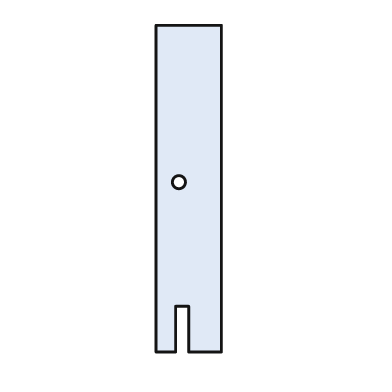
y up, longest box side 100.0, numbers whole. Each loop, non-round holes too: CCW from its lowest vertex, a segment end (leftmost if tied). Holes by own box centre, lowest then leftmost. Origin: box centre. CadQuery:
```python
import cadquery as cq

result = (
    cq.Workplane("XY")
    .moveTo(-10.0, -50.0)
    .lineTo(-4.0, -50.0)
    .lineTo(-4.0, -36.0)
    .lineTo(0.0, -36.0)
    .lineTo(0.0, -50.0)
    .lineTo(10.0, -50.0)
    .lineTo(10.0, 50.0)
    .lineTo(-10.0, 50.0)
    .close()
    .moveTo(-3.0, 2.0)
    .circle(2.0)
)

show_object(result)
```